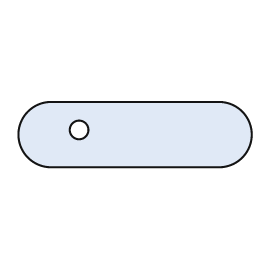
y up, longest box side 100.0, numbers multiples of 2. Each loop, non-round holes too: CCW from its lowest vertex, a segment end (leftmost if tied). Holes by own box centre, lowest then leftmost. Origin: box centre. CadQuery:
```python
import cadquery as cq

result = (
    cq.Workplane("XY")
    .moveTo(-36.0, -14.0)
    .lineTo(36.0, -14.0)
    .threePointArc((50.0, 0.0), (36.0, 14.0))
    .lineTo(-36.0, 14.0)
    .threePointArc((-50.0, 0.0), (-36.0, -14.0))
    .close()
    .moveTo(-24.0, 2.0)
    .circle(4.0)
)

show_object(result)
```